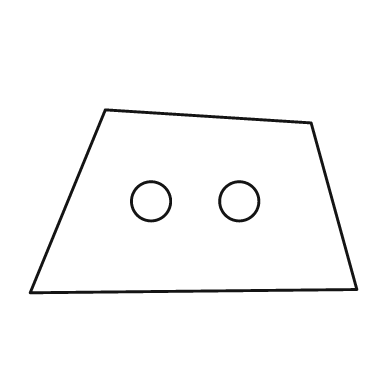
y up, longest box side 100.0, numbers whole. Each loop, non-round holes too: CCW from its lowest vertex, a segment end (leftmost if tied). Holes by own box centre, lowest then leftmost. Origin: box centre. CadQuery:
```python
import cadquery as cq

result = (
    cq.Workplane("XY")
    .moveTo(-50.0, -28.0)
    .lineTo(50.0, -27.0)
    .lineTo(36.0, 24.0)
    .lineTo(-27.0, 28.0)
    .close()
    .moveTo(-13.0, 0.0)
    .circle(6.0)
    .moveTo(14.0, 0.0)
    .circle(6.0)
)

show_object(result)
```